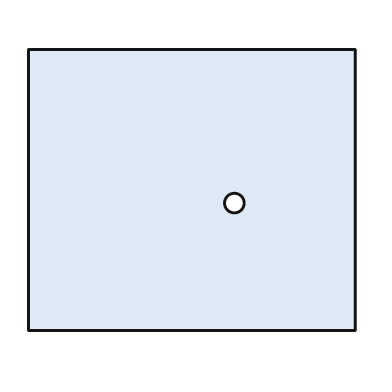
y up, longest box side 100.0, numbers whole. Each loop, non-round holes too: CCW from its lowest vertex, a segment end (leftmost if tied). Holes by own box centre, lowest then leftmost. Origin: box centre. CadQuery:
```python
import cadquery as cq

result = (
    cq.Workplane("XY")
    .moveTo(-50.0, -43.0)
    .lineTo(50.0, -43.0)
    .lineTo(50.0, 43.0)
    .lineTo(-50.0, 43.0)
    .close()
    .moveTo(13.0, -4.0)
    .circle(3.0)
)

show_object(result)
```